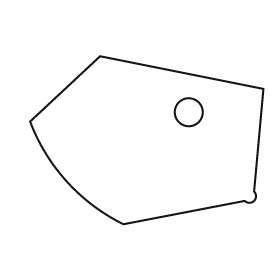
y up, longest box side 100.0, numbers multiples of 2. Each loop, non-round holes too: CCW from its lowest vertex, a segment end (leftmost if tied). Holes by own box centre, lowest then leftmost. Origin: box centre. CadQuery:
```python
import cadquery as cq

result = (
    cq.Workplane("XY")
    .moveTo(-10.0, -36.0)
    .lineTo(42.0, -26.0)
    .threePointArc((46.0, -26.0), (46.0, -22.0))
    .lineTo(50.0, 22.0)
    .lineTo(-20.0, 36.0)
    .lineTo(-50.0, 8.0)
    .threePointArc((-34.0, -18.0), (-10.0, -36.0))
    .close()
    .moveTo(18.0, 12.0)
    .circle(6.0)
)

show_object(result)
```